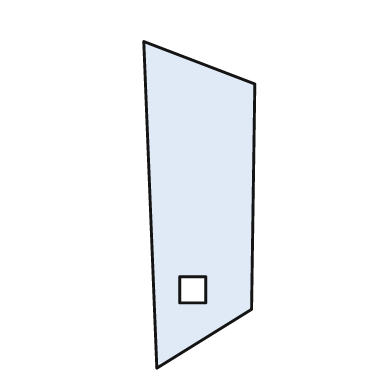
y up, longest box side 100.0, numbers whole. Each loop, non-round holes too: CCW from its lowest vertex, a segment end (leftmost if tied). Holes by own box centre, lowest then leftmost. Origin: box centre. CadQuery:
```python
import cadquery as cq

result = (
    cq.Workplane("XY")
    .moveTo(-13.0, -50.0)
    .lineTo(16.0, -32.0)
    .lineTo(17.0, 37.0)
    .lineTo(-17.0, 50.0)
    .close()
    .moveTo(-6.0, -30.0)
    .lineTo(2.0, -30.0)
    .lineTo(2.0, -22.0)
    .lineTo(-6.0, -22.0)
    .close()
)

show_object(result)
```